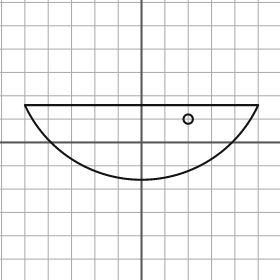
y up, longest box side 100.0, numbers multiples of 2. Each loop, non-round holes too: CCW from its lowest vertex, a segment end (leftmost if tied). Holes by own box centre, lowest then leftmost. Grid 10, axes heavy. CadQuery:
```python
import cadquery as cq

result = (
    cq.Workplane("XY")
    .moveTo(-50.0, 16.0)
    .threePointArc((0.0, -16.0), (50.0, 16.0))
    .close()
    .moveTo(20.0, 10.0)
    .circle(2.0)
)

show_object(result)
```